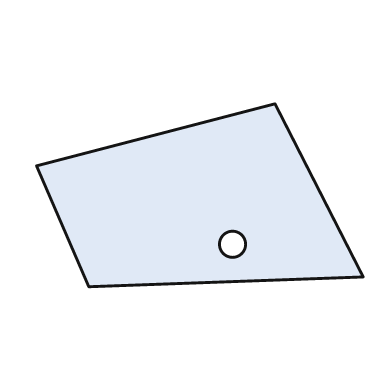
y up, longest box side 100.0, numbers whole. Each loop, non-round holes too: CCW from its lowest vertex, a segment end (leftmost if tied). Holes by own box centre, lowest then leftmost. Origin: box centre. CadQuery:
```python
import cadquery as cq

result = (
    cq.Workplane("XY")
    .moveTo(-34.0, -28.0)
    .lineTo(50.0, -25.0)
    .lineTo(23.0, 28.0)
    .lineTo(-50.0, 9.0)
    .close()
    .moveTo(10.0, -15.0)
    .circle(4.0)
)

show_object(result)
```